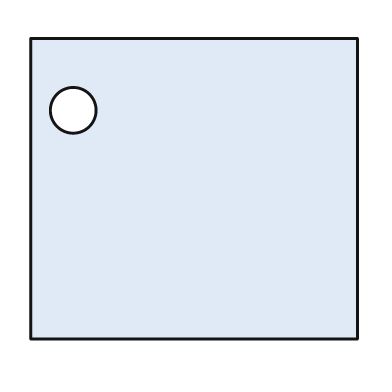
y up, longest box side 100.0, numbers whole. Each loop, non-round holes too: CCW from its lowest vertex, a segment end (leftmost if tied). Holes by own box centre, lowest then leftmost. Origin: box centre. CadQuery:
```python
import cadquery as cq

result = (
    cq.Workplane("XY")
    .moveTo(-50.0, -46.0)
    .lineTo(50.0, -46.0)
    .lineTo(50.0, 46.0)
    .lineTo(-50.0, 46.0)
    .close()
    .moveTo(-37.0, 24.0)
    .circle(7.0)
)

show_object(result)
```